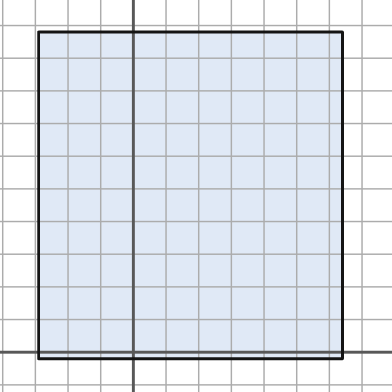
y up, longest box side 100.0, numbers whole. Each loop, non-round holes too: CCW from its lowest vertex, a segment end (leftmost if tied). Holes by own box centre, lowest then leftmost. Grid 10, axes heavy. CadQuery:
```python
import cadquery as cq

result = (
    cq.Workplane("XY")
    .moveTo(-29.0, -2.0)
    .lineTo(64.0, -2.0)
    .lineTo(64.0, 98.0)
    .lineTo(-29.0, 98.0)
    .close()
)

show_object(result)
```